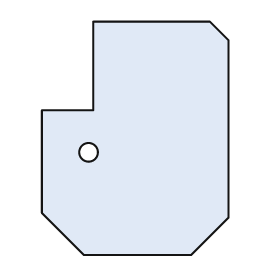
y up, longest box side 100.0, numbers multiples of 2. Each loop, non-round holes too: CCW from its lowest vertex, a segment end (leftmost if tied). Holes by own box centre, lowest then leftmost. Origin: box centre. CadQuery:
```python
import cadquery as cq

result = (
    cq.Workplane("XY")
    .moveTo(-22.0, -50.0)
    .lineTo(24.0, -50.0)
    .lineTo(40.0, -34.0)
    .lineTo(40.0, 42.0)
    .lineTo(32.0, 50.0)
    .lineTo(-18.0, 50.0)
    .lineTo(-18.0, 12.0)
    .lineTo(-40.0, 12.0)
    .lineTo(-40.0, -32.0)
    .close()
    .moveTo(-20.0, -6.0)
    .circle(4.0)
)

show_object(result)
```